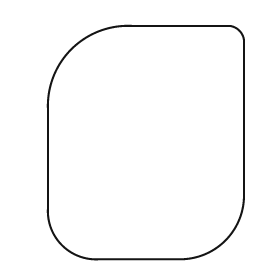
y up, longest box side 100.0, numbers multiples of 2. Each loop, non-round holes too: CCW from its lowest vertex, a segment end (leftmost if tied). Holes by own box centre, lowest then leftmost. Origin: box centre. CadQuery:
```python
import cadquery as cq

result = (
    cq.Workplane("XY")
    .moveTo(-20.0, -50.0)
    .lineTo(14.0, -50.0)
    .threePointArc((34.0, -42.0), (42.0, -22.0))
    .lineTo(42.0, 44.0)
    .threePointArc((40.0, 48.0), (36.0, 50.0))
    .lineTo(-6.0, 50.0)
    .threePointArc((-32.0, 40.0), (-42.0, 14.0))
    .lineTo(-42.0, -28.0)
    .threePointArc((-36.0, -44.0), (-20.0, -50.0))
    .close()
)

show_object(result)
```